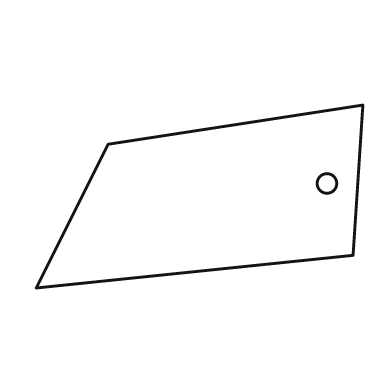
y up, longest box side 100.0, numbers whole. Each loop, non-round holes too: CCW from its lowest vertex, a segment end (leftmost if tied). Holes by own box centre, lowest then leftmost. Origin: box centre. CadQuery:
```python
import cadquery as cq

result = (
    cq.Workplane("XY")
    .moveTo(-50.0, -28.0)
    .lineTo(47.0, -18.0)
    .lineTo(50.0, 28.0)
    .lineTo(-28.0, 16.0)
    .close()
    .moveTo(39.0, 4.0)
    .circle(3.0)
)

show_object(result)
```